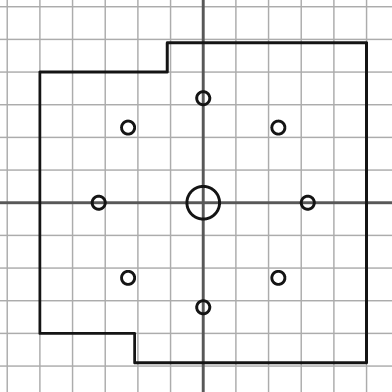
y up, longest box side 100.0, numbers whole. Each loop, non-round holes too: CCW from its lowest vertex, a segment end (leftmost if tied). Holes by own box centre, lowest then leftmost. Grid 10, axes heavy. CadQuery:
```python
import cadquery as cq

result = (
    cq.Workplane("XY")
    .moveTo(-21.0, -49.0)
    .lineTo(50.0, -49.0)
    .lineTo(50.0, 49.0)
    .lineTo(-11.0, 49.0)
    .lineTo(-11.0, 40.0)
    .lineTo(-50.0, 40.0)
    .lineTo(-50.0, -40.0)
    .lineTo(-21.0, -40.0)
    .close()
    .moveTo(0.0, -32.0)
    .circle(2.0)
    .moveTo(-23.0, -23.0)
    .circle(2.0)
    .moveTo(23.0, -23.0)
    .circle(2.0)
    .moveTo(-32.0, 0.0)
    .circle(2.0)
    .moveTo(0.0, 0.0)
    .circle(5.0)
    .moveTo(32.0, 0.0)
    .circle(2.0)
    .moveTo(-23.0, 23.0)
    .circle(2.0)
    .moveTo(23.0, 23.0)
    .circle(2.0)
    .moveTo(0.0, 32.0)
    .circle(2.0)
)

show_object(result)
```